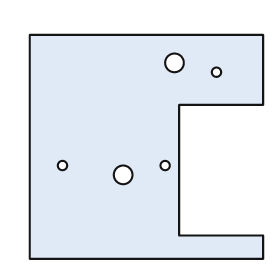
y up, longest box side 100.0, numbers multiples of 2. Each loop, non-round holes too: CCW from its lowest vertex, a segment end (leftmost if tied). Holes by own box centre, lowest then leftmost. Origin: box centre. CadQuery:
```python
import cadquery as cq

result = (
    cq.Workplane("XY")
    .moveTo(-50.0, -48.0)
    .lineTo(50.0, -48.0)
    .lineTo(50.0, -38.0)
    .lineTo(14.0, -38.0)
    .lineTo(14.0, 18.0)
    .lineTo(50.0, 18.0)
    .lineTo(50.0, 48.0)
    .lineTo(-50.0, 48.0)
    .close()
    .moveTo(-10.0, -12.0)
    .circle(4.0)
    .moveTo(-36.0, -8.0)
    .circle(2.0)
    .moveTo(8.0, -8.0)
    .circle(2.0)
    .moveTo(30.0, 32.0)
    .circle(2.0)
    .moveTo(12.0, 36.0)
    .circle(4.0)
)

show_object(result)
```